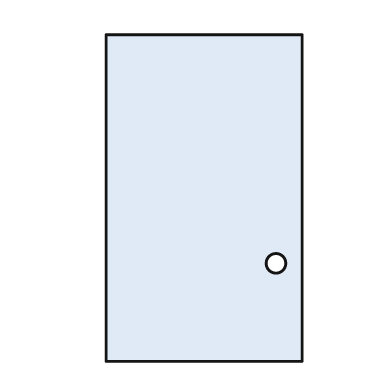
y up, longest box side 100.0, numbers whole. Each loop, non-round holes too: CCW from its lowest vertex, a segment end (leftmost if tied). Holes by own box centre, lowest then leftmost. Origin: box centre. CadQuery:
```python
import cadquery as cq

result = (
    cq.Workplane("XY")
    .moveTo(-30.0, -50.0)
    .lineTo(30.0, -50.0)
    .lineTo(30.0, 50.0)
    .lineTo(-30.0, 50.0)
    .close()
    .moveTo(22.0, -20.0)
    .circle(3.0)
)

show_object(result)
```